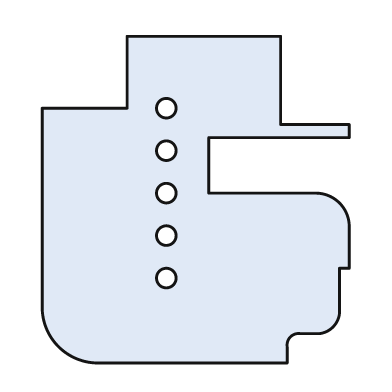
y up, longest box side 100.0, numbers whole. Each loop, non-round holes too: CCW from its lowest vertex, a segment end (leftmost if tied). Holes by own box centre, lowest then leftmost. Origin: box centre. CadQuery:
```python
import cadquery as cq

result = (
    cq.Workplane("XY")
    .moveTo(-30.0, -50.0)
    .lineTo(28.0, -50.0)
    .lineTo(28.0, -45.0)
    .threePointArc((29.0, -42.0), (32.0, -41.0))
    .lineTo(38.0, -41.0)
    .threePointArc((42.0, -39.0), (44.0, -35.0))
    .lineTo(44.0, -21.0)
    .lineTo(47.0, -21.0)
    .lineTo(47.0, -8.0)
    .threePointArc((44.0, -1.0), (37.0, 2.0))
    .lineTo(4.0, 2.0)
    .lineTo(4.0, 19.0)
    .lineTo(47.0, 19.0)
    .lineTo(47.0, 23.0)
    .lineTo(26.0, 23.0)
    .lineTo(26.0, 50.0)
    .lineTo(-21.0, 50.0)
    .lineTo(-21.0, 28.0)
    .lineTo(-47.0, 28.0)
    .lineTo(-47.0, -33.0)
    .threePointArc((-42.0, -45.0), (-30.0, -50.0))
    .close()
    .moveTo(-9.0, -24.0)
    .circle(3.0)
    .moveTo(-9.0, -11.0)
    .circle(3.0)
    .moveTo(-9.0, 2.0)
    .circle(3.0)
    .moveTo(-9.0, 15.0)
    .circle(3.0)
    .moveTo(-9.0, 28.0)
    .circle(3.0)
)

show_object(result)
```